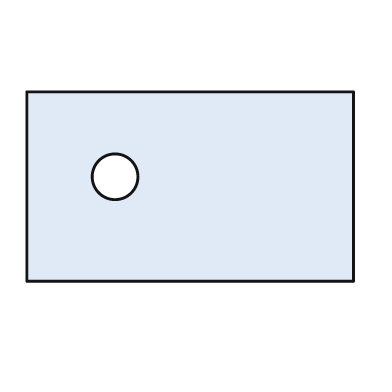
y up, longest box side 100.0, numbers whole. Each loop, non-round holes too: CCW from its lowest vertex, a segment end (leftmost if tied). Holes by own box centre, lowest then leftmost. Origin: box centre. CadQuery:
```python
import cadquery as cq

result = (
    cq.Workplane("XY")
    .moveTo(-50.0, -29.0)
    .lineTo(50.0, -29.0)
    .lineTo(50.0, 29.0)
    .lineTo(-50.0, 29.0)
    .close()
    .moveTo(-23.0, 3.0)
    .circle(7.0)
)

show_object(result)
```